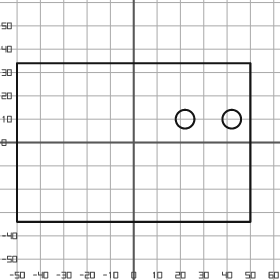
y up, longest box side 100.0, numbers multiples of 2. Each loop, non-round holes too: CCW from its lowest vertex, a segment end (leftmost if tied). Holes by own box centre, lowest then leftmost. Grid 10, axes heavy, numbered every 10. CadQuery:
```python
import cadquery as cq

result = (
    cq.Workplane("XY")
    .moveTo(-50.0, -34.0)
    .lineTo(50.0, -34.0)
    .lineTo(50.0, 34.0)
    .lineTo(-50.0, 34.0)
    .close()
    .moveTo(22.0, 10.0)
    .circle(4.0)
    .moveTo(42.0, 10.0)
    .circle(4.0)
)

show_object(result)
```